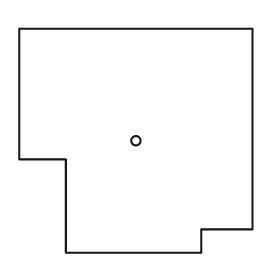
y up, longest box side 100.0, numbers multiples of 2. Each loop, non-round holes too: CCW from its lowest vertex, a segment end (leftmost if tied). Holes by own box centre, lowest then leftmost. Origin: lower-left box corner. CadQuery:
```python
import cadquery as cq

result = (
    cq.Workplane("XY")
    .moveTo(20.0, 0.0)
    .lineTo(78.0, 0.0)
    .lineTo(78.0, 10.0)
    .lineTo(100.0, 10.0)
    .lineTo(100.0, 96.0)
    .lineTo(0.0, 96.0)
    .lineTo(0.0, 40.0)
    .lineTo(20.0, 40.0)
    .close()
    .moveTo(50.0, 48.0)
    .circle(2.0)
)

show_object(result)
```